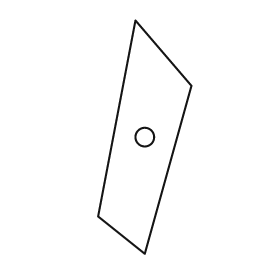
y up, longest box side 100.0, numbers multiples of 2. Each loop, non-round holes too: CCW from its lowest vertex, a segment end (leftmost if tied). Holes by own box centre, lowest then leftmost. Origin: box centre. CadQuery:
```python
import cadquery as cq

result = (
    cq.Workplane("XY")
    .moveTo(0.0, -50.0)
    .lineTo(20.0, 22.0)
    .lineTo(-4.0, 50.0)
    .lineTo(-20.0, -34.0)
    .close()
    .moveTo(0.0, 0.0)
    .circle(4.0)
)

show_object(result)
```